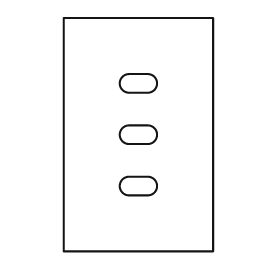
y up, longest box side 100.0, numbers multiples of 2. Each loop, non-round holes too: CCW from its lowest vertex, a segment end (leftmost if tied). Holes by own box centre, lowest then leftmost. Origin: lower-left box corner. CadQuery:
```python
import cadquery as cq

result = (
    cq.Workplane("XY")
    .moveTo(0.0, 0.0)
    .lineTo(64.0, 0.0)
    .lineTo(64.0, 100.0)
    .lineTo(0.0, 100.0)
    .close()
    .moveTo(28.0, 24.0)
    .lineTo(36.0, 24.0)
    .threePointArc((40.0, 28.0), (36.0, 32.0))
    .lineTo(28.0, 32.0)
    .threePointArc((24.0, 28.0), (28.0, 24.0))
    .close()
    .moveTo(28.0, 46.0)
    .lineTo(36.0, 46.0)
    .threePointArc((40.0, 50.0), (36.0, 54.0))
    .lineTo(28.0, 54.0)
    .threePointArc((24.0, 50.0), (28.0, 46.0))
    .close()
    .moveTo(28.0, 68.0)
    .lineTo(36.0, 68.0)
    .threePointArc((40.0, 72.0), (36.0, 76.0))
    .lineTo(28.0, 76.0)
    .threePointArc((24.0, 72.0), (28.0, 68.0))
    .close()
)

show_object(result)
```